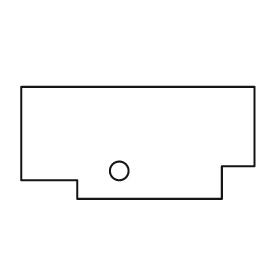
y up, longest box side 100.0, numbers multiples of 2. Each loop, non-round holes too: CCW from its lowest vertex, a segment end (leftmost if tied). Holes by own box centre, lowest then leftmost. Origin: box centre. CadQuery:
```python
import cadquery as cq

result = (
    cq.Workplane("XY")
    .moveTo(-26.0, -24.0)
    .lineTo(36.0, -24.0)
    .lineTo(36.0, -10.0)
    .lineTo(50.0, -10.0)
    .lineTo(50.0, 24.0)
    .lineTo(-50.0, 24.0)
    .lineTo(-50.0, -16.0)
    .lineTo(-26.0, -16.0)
    .close()
    .moveTo(-8.0, -12.0)
    .circle(4.0)
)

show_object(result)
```